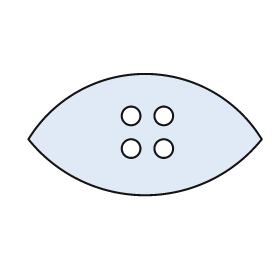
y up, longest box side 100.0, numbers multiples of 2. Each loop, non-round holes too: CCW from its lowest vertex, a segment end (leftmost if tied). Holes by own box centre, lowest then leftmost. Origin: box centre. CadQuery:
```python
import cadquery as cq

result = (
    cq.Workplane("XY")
    .moveTo(-50.0, -2.0)
    .threePointArc((0.0, -26.0), (50.0, -2.0))
    .threePointArc((0.0, 26.0), (-50.0, -2.0))
    .close()
    .moveTo(-6.0, -6.0)
    .circle(4.0)
    .moveTo(8.0, -6.0)
    .circle(4.0)
    .moveTo(-6.0, 8.0)
    .circle(4.0)
    .moveTo(8.0, 8.0)
    .circle(4.0)
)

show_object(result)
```